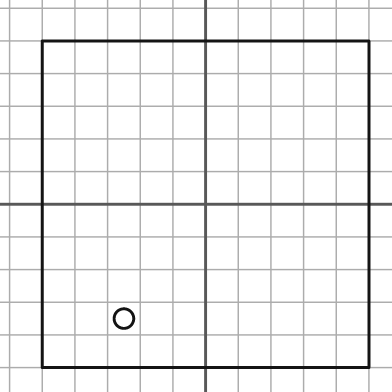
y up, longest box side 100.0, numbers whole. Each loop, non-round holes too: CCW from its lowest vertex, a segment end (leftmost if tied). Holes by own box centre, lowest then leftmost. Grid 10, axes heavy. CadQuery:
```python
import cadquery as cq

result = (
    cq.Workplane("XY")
    .moveTo(-50.0, -50.0)
    .lineTo(50.0, -50.0)
    .lineTo(50.0, 50.0)
    .lineTo(-50.0, 50.0)
    .close()
    .moveTo(-25.0, -35.0)
    .circle(3.0)
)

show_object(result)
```